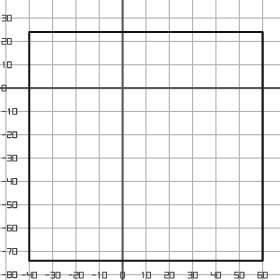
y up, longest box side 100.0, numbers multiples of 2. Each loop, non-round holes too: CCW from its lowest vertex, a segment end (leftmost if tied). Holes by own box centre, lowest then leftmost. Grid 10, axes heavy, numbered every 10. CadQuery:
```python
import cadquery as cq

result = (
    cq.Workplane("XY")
    .moveTo(-40.0, -74.0)
    .lineTo(60.0, -74.0)
    .lineTo(60.0, 24.0)
    .lineTo(-40.0, 24.0)
    .close()
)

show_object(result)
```